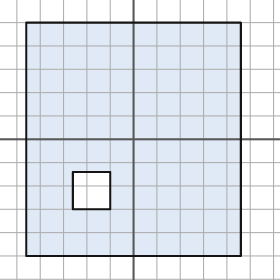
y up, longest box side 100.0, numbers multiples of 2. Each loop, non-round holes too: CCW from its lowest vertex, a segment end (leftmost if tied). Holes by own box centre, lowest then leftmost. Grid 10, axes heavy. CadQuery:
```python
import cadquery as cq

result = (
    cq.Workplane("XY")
    .moveTo(-46.0, -50.0)
    .lineTo(46.0, -50.0)
    .lineTo(46.0, 50.0)
    .lineTo(-46.0, 50.0)
    .close()
    .moveTo(-26.0, -30.0)
    .lineTo(-10.0, -30.0)
    .lineTo(-10.0, -14.0)
    .lineTo(-26.0, -14.0)
    .close()
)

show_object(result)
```